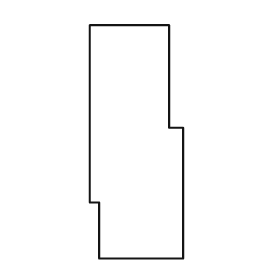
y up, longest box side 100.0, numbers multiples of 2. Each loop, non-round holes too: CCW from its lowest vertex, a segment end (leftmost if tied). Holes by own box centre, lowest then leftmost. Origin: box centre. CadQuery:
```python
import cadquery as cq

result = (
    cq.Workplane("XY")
    .moveTo(-16.0, -50.0)
    .lineTo(20.0, -50.0)
    .lineTo(20.0, 6.0)
    .lineTo(14.0, 6.0)
    .lineTo(14.0, 50.0)
    .lineTo(-20.0, 50.0)
    .lineTo(-20.0, -26.0)
    .lineTo(-16.0, -26.0)
    .close()
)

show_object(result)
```